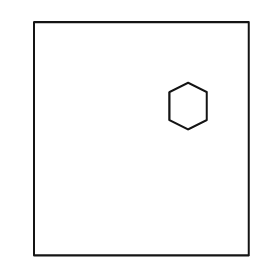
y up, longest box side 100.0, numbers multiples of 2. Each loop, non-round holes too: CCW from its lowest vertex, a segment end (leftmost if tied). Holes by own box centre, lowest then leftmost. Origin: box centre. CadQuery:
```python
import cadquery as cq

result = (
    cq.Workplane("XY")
    .moveTo(-46.0, -50.0)
    .lineTo(46.0, -50.0)
    .lineTo(46.0, 50.0)
    .lineTo(-46.0, 50.0)
    .close()
    .moveTo(20.0, 4.0)
    .lineTo(28.0, 8.0)
    .lineTo(28.0, 20.0)
    .lineTo(20.0, 24.0)
    .lineTo(12.0, 20.0)
    .lineTo(12.0, 8.0)
    .close()
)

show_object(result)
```